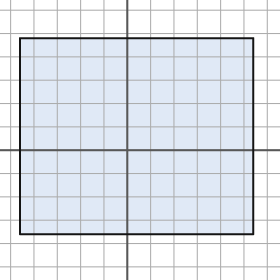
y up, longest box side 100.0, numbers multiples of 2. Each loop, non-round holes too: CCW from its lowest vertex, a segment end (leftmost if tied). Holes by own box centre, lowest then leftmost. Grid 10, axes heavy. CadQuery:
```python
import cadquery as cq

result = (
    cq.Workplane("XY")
    .moveTo(-46.0, -36.0)
    .lineTo(54.0, -36.0)
    .lineTo(54.0, 48.0)
    .lineTo(-46.0, 48.0)
    .close()
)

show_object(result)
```